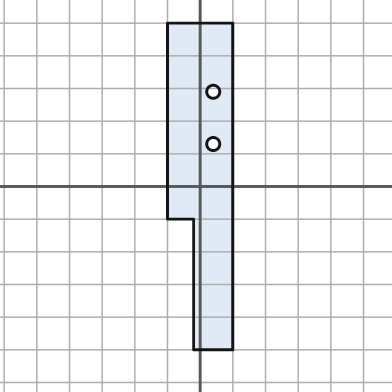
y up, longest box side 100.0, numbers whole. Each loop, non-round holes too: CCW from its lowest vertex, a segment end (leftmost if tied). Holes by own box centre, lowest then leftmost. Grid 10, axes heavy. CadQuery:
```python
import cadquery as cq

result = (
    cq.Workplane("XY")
    .moveTo(-2.0, -50.0)
    .lineTo(10.0, -50.0)
    .lineTo(10.0, 50.0)
    .lineTo(-10.0, 50.0)
    .lineTo(-10.0, -10.0)
    .lineTo(-2.0, -10.0)
    .close()
    .moveTo(4.0, 13.0)
    .circle(2.0)
    .moveTo(4.0, 29.0)
    .circle(2.0)
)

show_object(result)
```